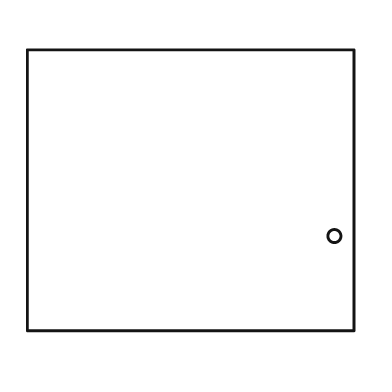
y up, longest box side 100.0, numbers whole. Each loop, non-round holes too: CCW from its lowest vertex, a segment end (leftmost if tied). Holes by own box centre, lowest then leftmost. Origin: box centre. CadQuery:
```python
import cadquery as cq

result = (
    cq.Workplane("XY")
    .moveTo(-50.0, -43.0)
    .lineTo(50.0, -43.0)
    .lineTo(50.0, 43.0)
    .lineTo(-50.0, 43.0)
    .close()
    .moveTo(44.0, -14.0)
    .circle(2.0)
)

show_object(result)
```